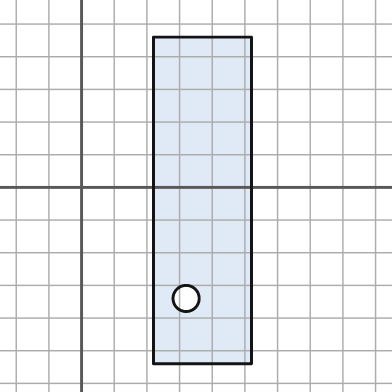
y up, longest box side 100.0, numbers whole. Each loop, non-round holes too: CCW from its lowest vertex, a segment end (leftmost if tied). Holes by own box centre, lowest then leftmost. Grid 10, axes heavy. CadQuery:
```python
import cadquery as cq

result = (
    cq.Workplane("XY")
    .moveTo(22.0, -54.0)
    .lineTo(52.0, -54.0)
    .lineTo(52.0, 46.0)
    .lineTo(22.0, 46.0)
    .close()
    .moveTo(32.0, -34.0)
    .circle(4.0)
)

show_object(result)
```